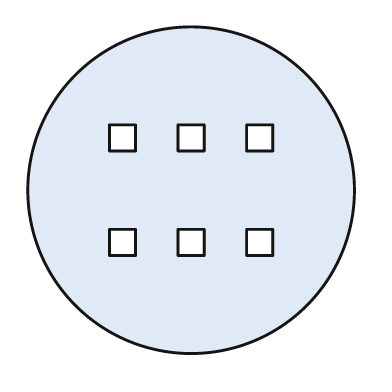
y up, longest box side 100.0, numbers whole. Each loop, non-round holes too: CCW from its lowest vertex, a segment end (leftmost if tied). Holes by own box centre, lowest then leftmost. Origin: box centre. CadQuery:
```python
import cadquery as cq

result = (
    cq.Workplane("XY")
    .moveTo(0.0, 0.0)
    .circle(50.0)
    .moveTo(-25.0, -20.0)
    .lineTo(-17.0, -20.0)
    .lineTo(-17.0, -12.0)
    .lineTo(-25.0, -12.0)
    .close()
    .moveTo(-4.0, -20.0)
    .lineTo(4.0, -20.0)
    .lineTo(4.0, -12.0)
    .lineTo(-4.0, -12.0)
    .close()
    .moveTo(17.0, -20.0)
    .lineTo(25.0, -20.0)
    .lineTo(25.0, -12.0)
    .lineTo(17.0, -12.0)
    .close()
    .moveTo(-25.0, 12.0)
    .lineTo(-17.0, 12.0)
    .lineTo(-17.0, 20.0)
    .lineTo(-25.0, 20.0)
    .close()
    .moveTo(-4.0, 12.0)
    .lineTo(4.0, 12.0)
    .lineTo(4.0, 20.0)
    .lineTo(-4.0, 20.0)
    .close()
    .moveTo(17.0, 12.0)
    .lineTo(25.0, 12.0)
    .lineTo(25.0, 20.0)
    .lineTo(17.0, 20.0)
    .close()
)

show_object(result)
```